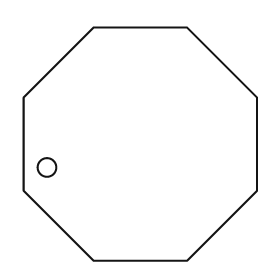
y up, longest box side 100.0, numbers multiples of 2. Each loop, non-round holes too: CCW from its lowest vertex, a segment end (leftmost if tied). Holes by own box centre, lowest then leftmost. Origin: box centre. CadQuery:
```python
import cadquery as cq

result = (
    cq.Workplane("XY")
    .moveTo(-20.0, -50.0)
    .lineTo(20.0, -50.0)
    .lineTo(50.0, -20.0)
    .lineTo(50.0, 20.0)
    .lineTo(20.0, 50.0)
    .lineTo(-20.0, 50.0)
    .lineTo(-50.0, 20.0)
    .lineTo(-50.0, -20.0)
    .close()
    .moveTo(-40.0, -10.0)
    .circle(4.0)
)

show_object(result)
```